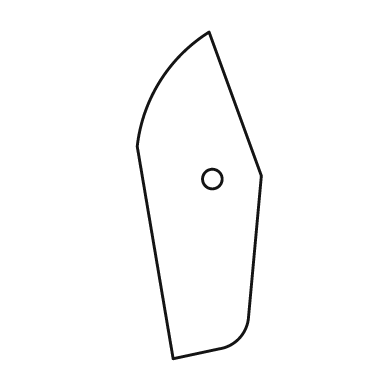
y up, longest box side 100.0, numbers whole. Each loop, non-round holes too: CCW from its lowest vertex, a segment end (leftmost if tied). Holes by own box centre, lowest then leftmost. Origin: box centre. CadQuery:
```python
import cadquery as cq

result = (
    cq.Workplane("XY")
    .moveTo(-8.0, -50.0)
    .lineTo(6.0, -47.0)
    .threePointArc((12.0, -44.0), (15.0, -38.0))
    .lineTo(19.0, 6.0)
    .lineTo(3.0, 50.0)
    .threePointArc((-12.0, 35.0), (-19.0, 15.0))
    .close()
    .moveTo(4.0, 5.0)
    .circle(3.0)
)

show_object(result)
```